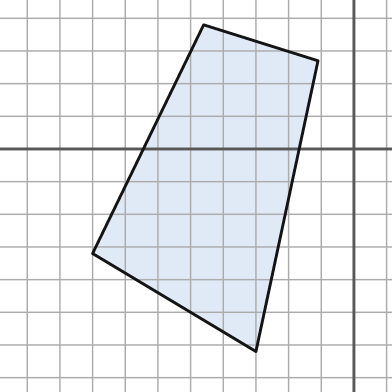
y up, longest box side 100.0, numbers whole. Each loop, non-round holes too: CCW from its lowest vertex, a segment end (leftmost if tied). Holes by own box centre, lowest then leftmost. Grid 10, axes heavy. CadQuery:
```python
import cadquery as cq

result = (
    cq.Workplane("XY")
    .moveTo(-30.0, -62.0)
    .lineTo(-11.0, 27.0)
    .lineTo(-46.0, 38.0)
    .lineTo(-80.0, -32.0)
    .close()
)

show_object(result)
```